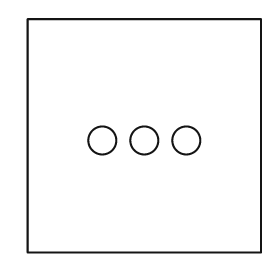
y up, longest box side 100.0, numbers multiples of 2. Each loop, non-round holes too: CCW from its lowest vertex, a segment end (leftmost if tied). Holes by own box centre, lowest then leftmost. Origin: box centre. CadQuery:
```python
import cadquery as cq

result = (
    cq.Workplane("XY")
    .moveTo(-50.0, -50.0)
    .lineTo(50.0, -50.0)
    .lineTo(50.0, 50.0)
    .lineTo(-50.0, 50.0)
    .close()
    .moveTo(-18.0, -2.0)
    .circle(6.0)
    .moveTo(0.0, -2.0)
    .circle(6.0)
    .moveTo(18.0, -2.0)
    .circle(6.0)
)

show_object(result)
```